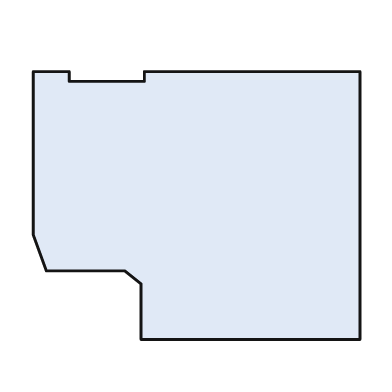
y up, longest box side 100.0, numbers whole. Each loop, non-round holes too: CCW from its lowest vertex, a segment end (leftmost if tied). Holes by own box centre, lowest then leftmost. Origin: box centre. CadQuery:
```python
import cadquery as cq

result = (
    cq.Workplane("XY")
    .moveTo(-17.0, -41.0)
    .lineTo(50.0, -41.0)
    .lineTo(50.0, 41.0)
    .lineTo(-16.0, 41.0)
    .lineTo(-16.0, 38.0)
    .lineTo(-39.0, 38.0)
    .lineTo(-39.0, 41.0)
    .lineTo(-50.0, 41.0)
    .lineTo(-50.0, -9.0)
    .lineTo(-46.0, -20.0)
    .lineTo(-22.0, -20.0)
    .lineTo(-17.0, -24.0)
    .close()
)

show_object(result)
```